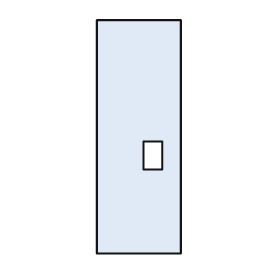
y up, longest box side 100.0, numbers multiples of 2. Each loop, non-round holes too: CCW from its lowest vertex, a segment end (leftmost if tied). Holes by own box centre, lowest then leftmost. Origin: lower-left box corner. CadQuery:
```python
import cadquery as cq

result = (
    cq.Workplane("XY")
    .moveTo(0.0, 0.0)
    .lineTo(36.0, 0.0)
    .lineTo(36.0, 100.0)
    .lineTo(0.0, 100.0)
    .close()
    .moveTo(20.0, 36.0)
    .lineTo(28.0, 36.0)
    .lineTo(28.0, 48.0)
    .lineTo(20.0, 48.0)
    .close()
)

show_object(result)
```